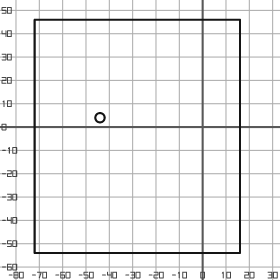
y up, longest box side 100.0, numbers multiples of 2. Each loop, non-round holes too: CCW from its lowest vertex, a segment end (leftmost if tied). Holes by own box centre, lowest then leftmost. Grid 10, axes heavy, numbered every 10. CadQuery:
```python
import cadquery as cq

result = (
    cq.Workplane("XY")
    .moveTo(-72.0, -54.0)
    .lineTo(16.0, -54.0)
    .lineTo(16.0, 46.0)
    .lineTo(-72.0, 46.0)
    .close()
    .moveTo(-44.0, 4.0)
    .circle(2.0)
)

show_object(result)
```